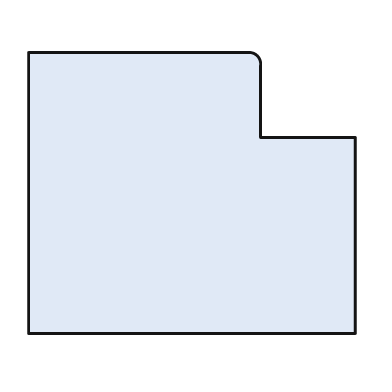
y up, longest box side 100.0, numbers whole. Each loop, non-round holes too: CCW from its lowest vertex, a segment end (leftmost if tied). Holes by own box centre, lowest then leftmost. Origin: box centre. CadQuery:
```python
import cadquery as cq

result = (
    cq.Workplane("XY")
    .moveTo(-50.0, -43.0)
    .lineTo(50.0, -43.0)
    .lineTo(50.0, 17.0)
    .lineTo(21.0, 17.0)
    .lineTo(21.0, 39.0)
    .threePointArc((20.0, 42.0), (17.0, 43.0))
    .lineTo(-50.0, 43.0)
    .close()
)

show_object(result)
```